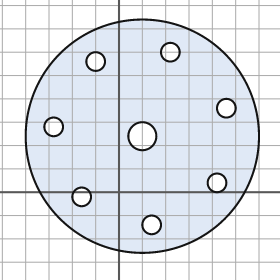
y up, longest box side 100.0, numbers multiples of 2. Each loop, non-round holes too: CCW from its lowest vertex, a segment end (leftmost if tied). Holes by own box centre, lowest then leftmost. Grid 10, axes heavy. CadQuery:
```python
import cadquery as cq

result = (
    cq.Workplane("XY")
    .moveTo(10.0, 24.0)
    .circle(50.0)
    .moveTo(14.0, -14.0)
    .circle(4.0)
    .moveTo(-16.0, -2.0)
    .circle(4.0)
    .moveTo(42.0, 4.0)
    .circle(4.0)
    .moveTo(10.0, 24.0)
    .circle(6.0)
    .moveTo(-28.0, 28.0)
    .circle(4.0)
    .moveTo(46.0, 36.0)
    .circle(4.0)
    .moveTo(-10.0, 56.0)
    .circle(4.0)
    .moveTo(22.0, 60.0)
    .circle(4.0)
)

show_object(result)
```